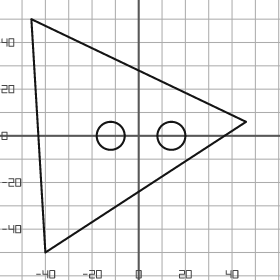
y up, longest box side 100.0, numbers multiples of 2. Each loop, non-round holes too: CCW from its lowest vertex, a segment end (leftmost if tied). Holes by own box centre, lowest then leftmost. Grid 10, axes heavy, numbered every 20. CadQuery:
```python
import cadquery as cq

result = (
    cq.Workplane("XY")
    .moveTo(-40.0, -50.0)
    .lineTo(46.0, 6.0)
    .lineTo(-46.0, 50.0)
    .close()
    .moveTo(-12.0, 0.0)
    .circle(6.0)
    .moveTo(14.0, 0.0)
    .circle(6.0)
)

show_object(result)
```